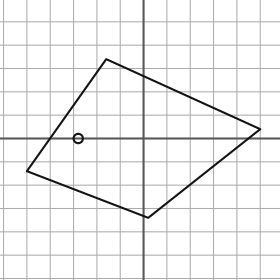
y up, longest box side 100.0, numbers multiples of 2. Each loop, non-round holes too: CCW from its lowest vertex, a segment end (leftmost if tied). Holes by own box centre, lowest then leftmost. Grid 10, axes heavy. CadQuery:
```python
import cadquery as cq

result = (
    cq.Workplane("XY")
    .moveTo(2.0, -34.0)
    .lineTo(50.0, 4.0)
    .lineTo(-16.0, 34.0)
    .lineTo(-50.0, -14.0)
    .close()
    .moveTo(-28.0, 0.0)
    .circle(2.0)
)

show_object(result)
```